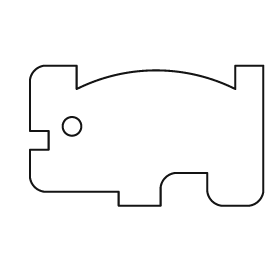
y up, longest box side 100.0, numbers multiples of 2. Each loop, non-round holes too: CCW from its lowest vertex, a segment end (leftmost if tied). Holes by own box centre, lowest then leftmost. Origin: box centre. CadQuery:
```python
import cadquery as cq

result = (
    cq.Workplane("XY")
    .moveTo(-12.0, -30.0)
    .lineTo(6.0, -30.0)
    .lineTo(6.0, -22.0)
    .threePointArc((8.0, -18.0), (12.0, -16.0))
    .lineTo(26.0, -16.0)
    .lineTo(26.0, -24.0)
    .threePointArc((28.0, -28.0), (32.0, -30.0))
    .lineTo(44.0, -30.0)
    .threePointArc((48.0, -28.0), (50.0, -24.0))
    .lineTo(50.0, 30.0)
    .lineTo(38.0, 30.0)
    .lineTo(38.0, 20.0)
    .threePointArc((4.0, 28.0), (-30.0, 20.0))
    .lineTo(-30.0, 30.0)
    .lineTo(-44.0, 30.0)
    .threePointArc((-48.0, 28.0), (-50.0, 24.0))
    .lineTo(-50.0, 2.0)
    .lineTo(-42.0, 2.0)
    .lineTo(-42.0, -6.0)
    .lineTo(-50.0, -6.0)
    .lineTo(-50.0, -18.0)
    .threePointArc((-48.0, -22.0), (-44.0, -24.0))
    .lineTo(-12.0, -24.0)
    .close()
    .moveTo(-32.0, 4.0)
    .circle(4.0)
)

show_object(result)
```